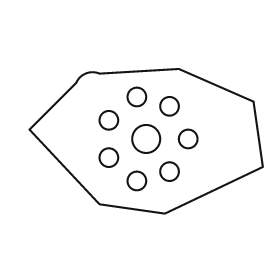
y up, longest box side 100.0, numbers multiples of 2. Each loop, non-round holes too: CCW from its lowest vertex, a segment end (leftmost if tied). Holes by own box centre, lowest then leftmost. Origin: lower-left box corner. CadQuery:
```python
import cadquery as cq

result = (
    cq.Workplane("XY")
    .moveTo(58.0, 0.0)
    .lineTo(100.0, 20.0)
    .lineTo(96.0, 48.0)
    .lineTo(64.0, 62.0)
    .lineTo(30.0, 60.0)
    .threePointArc((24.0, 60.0), (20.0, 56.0))
    .lineTo(0.0, 36.0)
    .lineTo(30.0, 4.0)
    .close()
    .moveTo(46.0, 14.0)
    .circle(4.0)
    .moveTo(60.0, 18.0)
    .circle(4.0)
    .moveTo(34.0, 24.0)
    .circle(4.0)
    .moveTo(50.0, 32.0)
    .circle(6.0)
    .moveTo(68.0, 32.0)
    .circle(4.0)
    .moveTo(34.0, 40.0)
    .circle(4.0)
    .moveTo(60.0, 46.0)
    .circle(4.0)
    .moveTo(46.0, 50.0)
    .circle(4.0)
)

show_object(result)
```